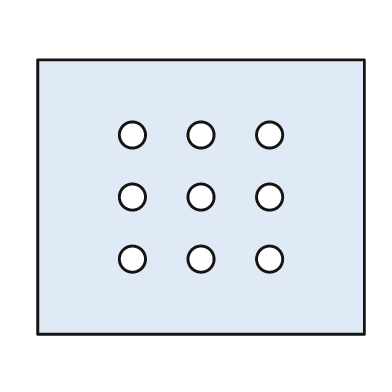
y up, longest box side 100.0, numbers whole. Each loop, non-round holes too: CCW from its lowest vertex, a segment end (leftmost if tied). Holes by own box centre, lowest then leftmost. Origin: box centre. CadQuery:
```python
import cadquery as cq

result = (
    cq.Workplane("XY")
    .moveTo(-50.0, -42.0)
    .lineTo(50.0, -42.0)
    .lineTo(50.0, 42.0)
    .lineTo(-50.0, 42.0)
    .close()
    .moveTo(-21.0, -19.0)
    .circle(4.0)
    .moveTo(0.0, -19.0)
    .circle(4.0)
    .moveTo(21.0, -19.0)
    .circle(4.0)
    .moveTo(-21.0, 0.0)
    .circle(4.0)
    .moveTo(0.0, 0.0)
    .circle(4.0)
    .moveTo(21.0, 0.0)
    .circle(4.0)
    .moveTo(-21.0, 19.0)
    .circle(4.0)
    .moveTo(0.0, 19.0)
    .circle(4.0)
    .moveTo(21.0, 19.0)
    .circle(4.0)
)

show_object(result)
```